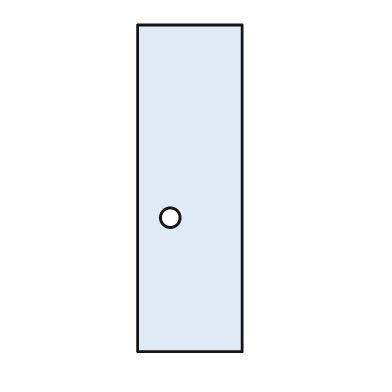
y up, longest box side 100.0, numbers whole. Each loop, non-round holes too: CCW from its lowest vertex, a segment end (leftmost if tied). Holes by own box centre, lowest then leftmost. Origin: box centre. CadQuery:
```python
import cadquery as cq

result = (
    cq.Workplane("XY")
    .moveTo(-16.0, -50.0)
    .lineTo(16.0, -50.0)
    .lineTo(16.0, 50.0)
    .lineTo(-16.0, 50.0)
    .close()
    .moveTo(-6.0, -9.0)
    .circle(3.0)
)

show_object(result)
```